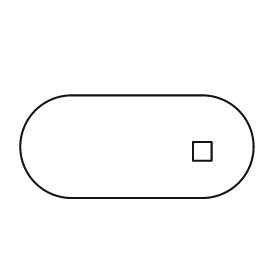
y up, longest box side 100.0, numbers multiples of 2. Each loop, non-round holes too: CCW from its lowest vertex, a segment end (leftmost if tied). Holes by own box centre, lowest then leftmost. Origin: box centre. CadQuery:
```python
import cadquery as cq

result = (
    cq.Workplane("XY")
    .moveTo(-28.0, -22.0)
    .lineTo(28.0, -22.0)
    .threePointArc((50.0, 0.0), (28.0, 22.0))
    .lineTo(-28.0, 22.0)
    .threePointArc((-50.0, 0.0), (-28.0, -22.0))
    .close()
    .moveTo(24.0, -6.0)
    .lineTo(32.0, -6.0)
    .lineTo(32.0, 2.0)
    .lineTo(24.0, 2.0)
    .close()
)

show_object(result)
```